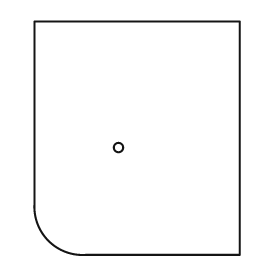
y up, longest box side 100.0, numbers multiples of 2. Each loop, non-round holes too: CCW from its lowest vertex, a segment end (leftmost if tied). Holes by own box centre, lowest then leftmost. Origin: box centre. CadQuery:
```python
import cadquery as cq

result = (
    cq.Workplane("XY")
    .moveTo(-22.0, -50.0)
    .lineTo(44.0, -50.0)
    .lineTo(44.0, 50.0)
    .lineTo(-44.0, 50.0)
    .lineTo(-44.0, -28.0)
    .threePointArc((-38.0, -44.0), (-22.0, -50.0))
    .close()
    .moveTo(-8.0, -4.0)
    .circle(2.0)
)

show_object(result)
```